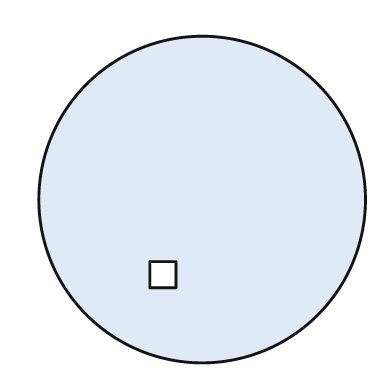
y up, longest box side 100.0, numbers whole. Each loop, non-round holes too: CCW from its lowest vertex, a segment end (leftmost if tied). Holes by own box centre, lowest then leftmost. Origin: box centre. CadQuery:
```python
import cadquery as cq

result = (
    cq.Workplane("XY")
    .moveTo(0.0, 0.0)
    .circle(50.0)
    .moveTo(-16.0, -27.0)
    .lineTo(-8.0, -27.0)
    .lineTo(-8.0, -19.0)
    .lineTo(-16.0, -19.0)
    .close()
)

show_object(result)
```